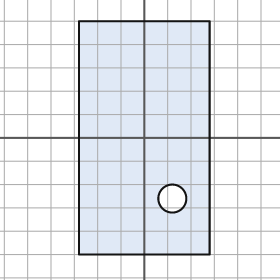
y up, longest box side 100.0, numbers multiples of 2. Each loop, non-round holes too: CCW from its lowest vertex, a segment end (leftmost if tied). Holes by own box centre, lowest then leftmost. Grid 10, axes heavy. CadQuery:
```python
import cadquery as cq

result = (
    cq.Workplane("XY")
    .moveTo(-28.0, -50.0)
    .lineTo(28.0, -50.0)
    .lineTo(28.0, 50.0)
    .lineTo(-28.0, 50.0)
    .close()
    .moveTo(12.0, -26.0)
    .circle(6.0)
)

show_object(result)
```